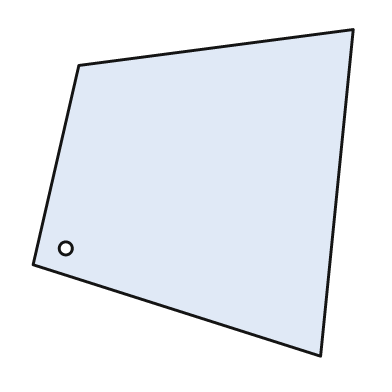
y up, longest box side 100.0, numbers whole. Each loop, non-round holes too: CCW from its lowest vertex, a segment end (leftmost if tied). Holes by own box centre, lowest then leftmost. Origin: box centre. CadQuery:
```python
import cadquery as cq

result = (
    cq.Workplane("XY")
    .moveTo(39.0, -50.0)
    .lineTo(49.0, 50.0)
    .lineTo(-35.0, 39.0)
    .lineTo(-49.0, -22.0)
    .close()
    .moveTo(-39.0, -17.0)
    .circle(2.0)
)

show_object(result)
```